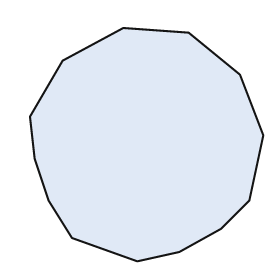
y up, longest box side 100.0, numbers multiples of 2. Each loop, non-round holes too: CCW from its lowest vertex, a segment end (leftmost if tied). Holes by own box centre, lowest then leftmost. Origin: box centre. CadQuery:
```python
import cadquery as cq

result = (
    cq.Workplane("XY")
    .moveTo(-4.0, -50.0)
    .lineTo(14.0, -46.0)
    .lineTo(32.0, -36.0)
    .lineTo(44.0, -24.0)
    .lineTo(50.0, 4.0)
    .lineTo(40.0, 30.0)
    .lineTo(18.0, 48.0)
    .lineTo(-10.0, 50.0)
    .lineTo(-36.0, 36.0)
    .lineTo(-50.0, 12.0)
    .lineTo(-48.0, -6.0)
    .lineTo(-42.0, -24.0)
    .lineTo(-32.0, -40.0)
    .close()
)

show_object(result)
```